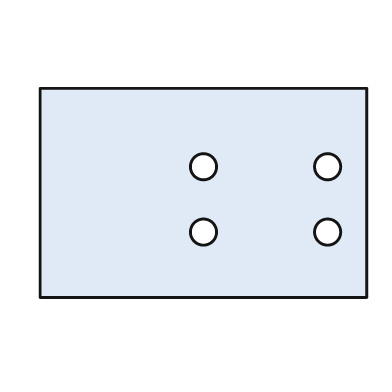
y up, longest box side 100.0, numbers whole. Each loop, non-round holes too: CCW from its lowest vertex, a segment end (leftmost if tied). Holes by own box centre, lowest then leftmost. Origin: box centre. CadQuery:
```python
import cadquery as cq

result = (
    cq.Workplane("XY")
    .moveTo(-50.0, -32.0)
    .lineTo(50.0, -32.0)
    .lineTo(50.0, 32.0)
    .lineTo(-50.0, 32.0)
    .close()
    .moveTo(0.0, -12.0)
    .circle(4.0)
    .moveTo(38.0, -12.0)
    .circle(4.0)
    .moveTo(0.0, 8.0)
    .circle(4.0)
    .moveTo(38.0, 8.0)
    .circle(4.0)
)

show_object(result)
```